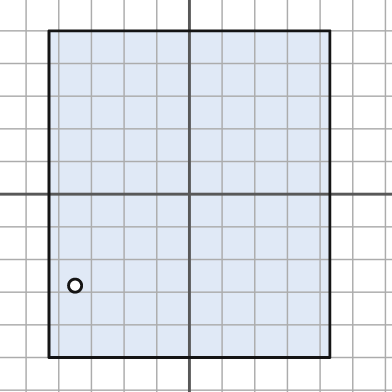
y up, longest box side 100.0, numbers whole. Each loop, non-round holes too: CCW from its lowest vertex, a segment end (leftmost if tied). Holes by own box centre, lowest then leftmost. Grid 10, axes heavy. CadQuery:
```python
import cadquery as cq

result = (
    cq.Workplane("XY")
    .moveTo(-43.0, -50.0)
    .lineTo(43.0, -50.0)
    .lineTo(43.0, 50.0)
    .lineTo(-43.0, 50.0)
    .close()
    .moveTo(-35.0, -28.0)
    .circle(2.0)
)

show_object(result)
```